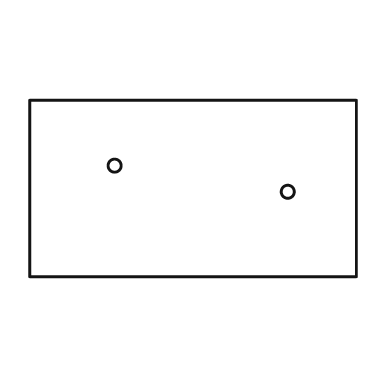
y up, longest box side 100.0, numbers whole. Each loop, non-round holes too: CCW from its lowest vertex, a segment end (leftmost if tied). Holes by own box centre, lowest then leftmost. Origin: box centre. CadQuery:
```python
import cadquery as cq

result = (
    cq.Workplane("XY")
    .moveTo(-50.0, -27.0)
    .lineTo(50.0, -27.0)
    .lineTo(50.0, 27.0)
    .lineTo(-50.0, 27.0)
    .close()
    .moveTo(29.0, -1.0)
    .circle(2.0)
    .moveTo(-24.0, 7.0)
    .circle(2.0)
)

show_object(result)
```